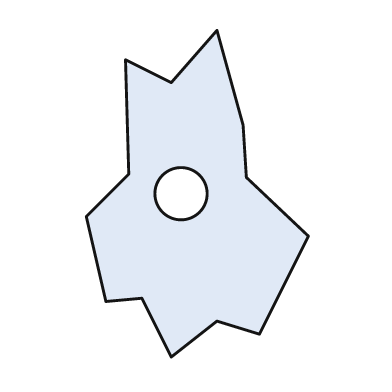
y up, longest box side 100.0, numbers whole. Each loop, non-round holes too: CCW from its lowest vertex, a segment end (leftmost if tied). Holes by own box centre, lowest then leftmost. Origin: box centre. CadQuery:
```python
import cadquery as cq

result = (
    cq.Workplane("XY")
    .moveTo(-8.0, -50.0)
    .lineTo(6.0, -39.0)
    .lineTo(19.0, -43.0)
    .lineTo(34.0, -13.0)
    .lineTo(15.0, 5.0)
    .lineTo(14.0, 21.0)
    .lineTo(6.0, 50.0)
    .lineTo(-8.0, 34.0)
    .lineTo(-22.0, 41.0)
    .lineTo(-21.0, 6.0)
    .lineTo(-34.0, -7.0)
    .lineTo(-28.0, -33.0)
    .lineTo(-17.0, -32.0)
    .close()
    .moveTo(-5.0, 0.0)
    .circle(8.0)
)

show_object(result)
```